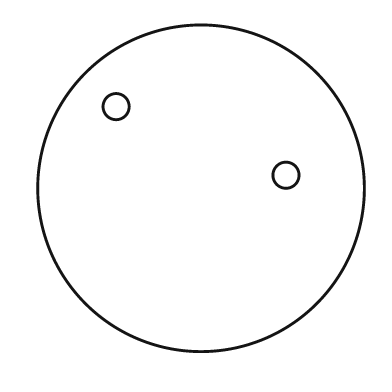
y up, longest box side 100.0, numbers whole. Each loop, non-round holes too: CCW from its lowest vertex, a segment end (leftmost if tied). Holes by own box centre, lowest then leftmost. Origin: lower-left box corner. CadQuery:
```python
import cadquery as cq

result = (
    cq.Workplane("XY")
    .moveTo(50.0, 50.0)
    .circle(50.0)
    .moveTo(76.0, 54.0)
    .circle(4.0)
    .moveTo(24.0, 75.0)
    .circle(4.0)
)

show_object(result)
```